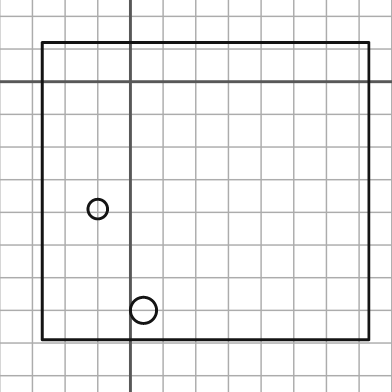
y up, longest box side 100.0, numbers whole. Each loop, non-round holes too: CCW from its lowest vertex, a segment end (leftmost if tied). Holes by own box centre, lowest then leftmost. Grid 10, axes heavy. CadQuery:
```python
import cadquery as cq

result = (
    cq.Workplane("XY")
    .moveTo(-27.0, -79.0)
    .lineTo(73.0, -79.0)
    .lineTo(73.0, 12.0)
    .lineTo(-27.0, 12.0)
    .close()
    .moveTo(4.0, -70.0)
    .circle(4.0)
    .moveTo(-10.0, -39.0)
    .circle(3.0)
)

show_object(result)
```